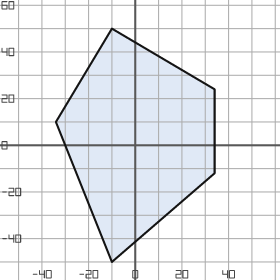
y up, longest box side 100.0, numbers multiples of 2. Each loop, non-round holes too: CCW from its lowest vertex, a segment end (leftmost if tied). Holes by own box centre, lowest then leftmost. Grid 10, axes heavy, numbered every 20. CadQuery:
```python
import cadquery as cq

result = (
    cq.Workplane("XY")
    .moveTo(-10.0, -50.0)
    .lineTo(34.0, -12.0)
    .lineTo(34.0, 24.0)
    .lineTo(-10.0, 50.0)
    .lineTo(-34.0, 10.0)
    .close()
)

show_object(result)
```